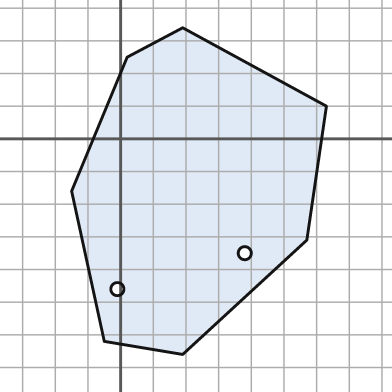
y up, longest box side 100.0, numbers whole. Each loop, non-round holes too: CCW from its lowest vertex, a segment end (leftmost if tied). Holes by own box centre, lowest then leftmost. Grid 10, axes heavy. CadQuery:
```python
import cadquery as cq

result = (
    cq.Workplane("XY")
    .moveTo(19.0, -66.0)
    .lineTo(57.0, -31.0)
    .lineTo(63.0, 10.0)
    .lineTo(19.0, 34.0)
    .lineTo(2.0, 25.0)
    .lineTo(-15.0, -16.0)
    .lineTo(-5.0, -62.0)
    .close()
    .moveTo(-1.0, -46.0)
    .circle(2.0)
    .moveTo(38.0, -35.0)
    .circle(2.0)
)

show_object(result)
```